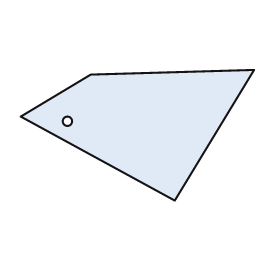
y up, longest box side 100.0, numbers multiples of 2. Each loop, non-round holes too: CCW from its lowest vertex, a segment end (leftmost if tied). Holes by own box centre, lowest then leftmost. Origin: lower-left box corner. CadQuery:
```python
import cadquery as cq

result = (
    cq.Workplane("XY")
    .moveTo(66.0, 0.0)
    .lineTo(100.0, 56.0)
    .lineTo(30.0, 54.0)
    .lineTo(0.0, 36.0)
    .close()
    .moveTo(20.0, 34.0)
    .circle(2.0)
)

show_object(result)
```